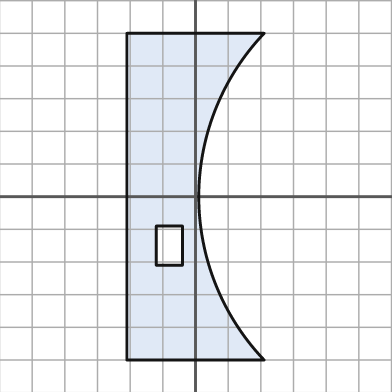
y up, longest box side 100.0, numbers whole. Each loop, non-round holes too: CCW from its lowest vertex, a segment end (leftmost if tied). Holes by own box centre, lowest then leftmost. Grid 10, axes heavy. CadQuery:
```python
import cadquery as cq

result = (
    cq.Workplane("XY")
    .moveTo(-21.0, -50.0)
    .lineTo(21.0, -50.0)
    .threePointArc((1.0, 0.0), (21.0, 50.0))
    .lineTo(-21.0, 50.0)
    .close()
    .moveTo(-12.0, -21.0)
    .lineTo(-4.0, -21.0)
    .lineTo(-4.0, -9.0)
    .lineTo(-12.0, -9.0)
    .close()
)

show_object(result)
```